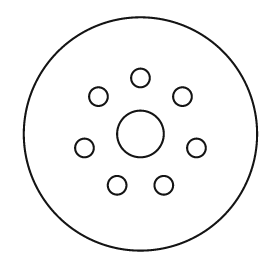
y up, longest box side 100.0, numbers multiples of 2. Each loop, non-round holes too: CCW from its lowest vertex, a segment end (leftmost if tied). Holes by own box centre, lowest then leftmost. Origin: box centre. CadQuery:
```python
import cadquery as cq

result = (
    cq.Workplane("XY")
    .moveTo(0.0, 0.0)
    .circle(50.0)
    .moveTo(-10.0, -22.0)
    .circle(4.0)
    .moveTo(10.0, -22.0)
    .circle(4.0)
    .moveTo(-24.0, -6.0)
    .circle(4.0)
    .moveTo(24.0, -6.0)
    .circle(4.0)
    .moveTo(0.0, 0.0)
    .circle(10.0)
    .moveTo(-18.0, 16.0)
    .circle(4.0)
    .moveTo(18.0, 16.0)
    .circle(4.0)
    .moveTo(0.0, 24.0)
    .circle(4.0)
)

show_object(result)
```